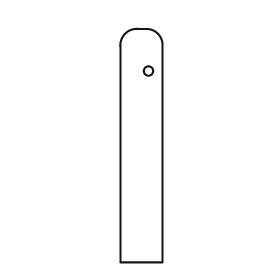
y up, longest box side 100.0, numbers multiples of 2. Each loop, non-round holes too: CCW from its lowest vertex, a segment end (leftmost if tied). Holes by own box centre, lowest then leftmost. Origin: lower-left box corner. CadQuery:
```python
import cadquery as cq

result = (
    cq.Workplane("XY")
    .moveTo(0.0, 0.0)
    .lineTo(18.0, 0.0)
    .lineTo(18.0, 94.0)
    .threePointArc((16.0, 98.0), (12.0, 100.0))
    .lineTo(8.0, 100.0)
    .threePointArc((2.0, 98.0), (0.0, 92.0))
    .close()
    .moveTo(12.0, 82.0)
    .circle(2.0)
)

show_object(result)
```